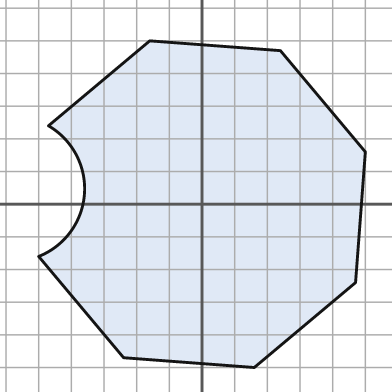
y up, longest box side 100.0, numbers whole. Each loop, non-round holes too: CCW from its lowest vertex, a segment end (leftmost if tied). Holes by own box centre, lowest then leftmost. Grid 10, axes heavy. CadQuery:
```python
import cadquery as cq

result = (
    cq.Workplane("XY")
    .moveTo(16.0, -50.0)
    .lineTo(47.0, -24.0)
    .lineTo(50.0, 16.0)
    .lineTo(24.0, 47.0)
    .lineTo(-16.0, 50.0)
    .lineTo(-47.0, 24.0)
    .threePointArc((-36.0, 3.0), (-50.0, -16.0))
    .lineTo(-24.0, -47.0)
    .close()
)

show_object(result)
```